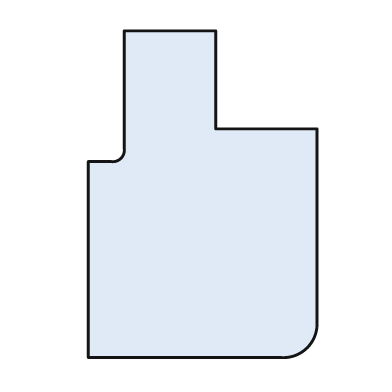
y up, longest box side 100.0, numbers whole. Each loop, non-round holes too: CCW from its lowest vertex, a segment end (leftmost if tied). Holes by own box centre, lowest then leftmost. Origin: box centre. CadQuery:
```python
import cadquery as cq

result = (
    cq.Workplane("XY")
    .moveTo(-35.0, -50.0)
    .lineTo(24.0, -50.0)
    .threePointArc((32.0, -47.0), (35.0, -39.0))
    .lineTo(35.0, 20.0)
    .lineTo(4.0, 20.0)
    .lineTo(4.0, 50.0)
    .lineTo(-24.0, 50.0)
    .lineTo(-24.0, 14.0)
    .threePointArc((-25.0, 11.0), (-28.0, 10.0))
    .lineTo(-35.0, 10.0)
    .close()
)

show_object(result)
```